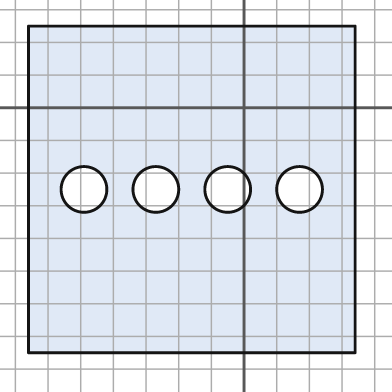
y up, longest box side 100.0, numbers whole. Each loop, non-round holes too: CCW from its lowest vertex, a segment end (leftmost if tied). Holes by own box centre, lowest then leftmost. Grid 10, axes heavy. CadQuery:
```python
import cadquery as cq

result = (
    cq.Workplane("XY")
    .moveTo(-66.0, -75.0)
    .lineTo(34.0, -75.0)
    .lineTo(34.0, 25.0)
    .lineTo(-66.0, 25.0)
    .close()
    .moveTo(-49.0, -25.0)
    .circle(7.0)
    .moveTo(-27.0, -25.0)
    .circle(7.0)
    .moveTo(-5.0, -25.0)
    .circle(7.0)
    .moveTo(17.0, -25.0)
    .circle(7.0)
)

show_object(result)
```